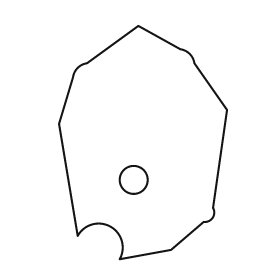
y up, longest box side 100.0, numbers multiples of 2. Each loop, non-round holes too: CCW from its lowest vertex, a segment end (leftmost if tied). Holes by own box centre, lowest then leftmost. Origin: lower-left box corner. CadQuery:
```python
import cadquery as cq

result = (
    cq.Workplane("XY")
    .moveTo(26.0, 0.0)
    .lineTo(48.0, 4.0)
    .lineTo(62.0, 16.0)
    .threePointArc((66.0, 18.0), (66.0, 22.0))
    .lineTo(72.0, 64.0)
    .lineTo(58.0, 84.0)
    .threePointArc((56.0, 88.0), (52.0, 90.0))
    .lineTo(34.0, 100.0)
    .lineTo(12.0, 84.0)
    .threePointArc((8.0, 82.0), (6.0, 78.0))
    .lineTo(0.0, 58.0)
    .lineTo(8.0, 10.0)
    .threePointArc((22.0, 14.0), (26.0, 0.0))
    .close()
    .moveTo(32.0, 34.0)
    .circle(6.0)
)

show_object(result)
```